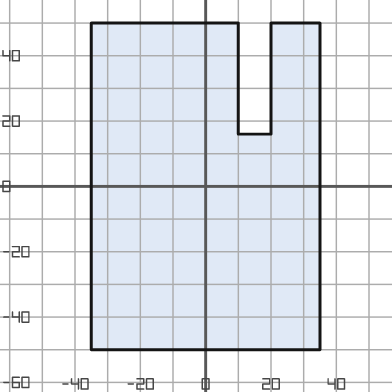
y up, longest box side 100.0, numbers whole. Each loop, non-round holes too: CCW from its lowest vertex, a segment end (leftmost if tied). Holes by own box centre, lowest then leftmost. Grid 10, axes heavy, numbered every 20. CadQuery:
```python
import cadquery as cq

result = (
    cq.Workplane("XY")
    .moveTo(-35.0, -50.0)
    .lineTo(35.0, -50.0)
    .lineTo(35.0, 50.0)
    .lineTo(20.0, 50.0)
    .lineTo(20.0, 16.0)
    .lineTo(10.0, 16.0)
    .lineTo(10.0, 50.0)
    .lineTo(-35.0, 50.0)
    .close()
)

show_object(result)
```